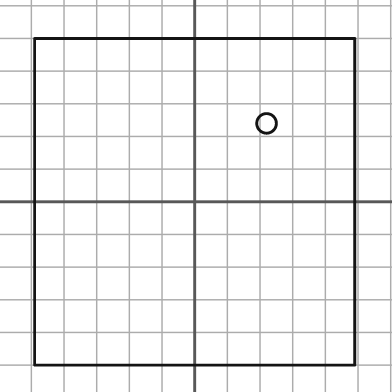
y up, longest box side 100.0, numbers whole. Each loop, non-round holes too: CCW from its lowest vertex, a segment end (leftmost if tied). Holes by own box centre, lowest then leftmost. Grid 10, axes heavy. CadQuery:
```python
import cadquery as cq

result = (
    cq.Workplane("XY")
    .moveTo(-49.0, -50.0)
    .lineTo(49.0, -50.0)
    .lineTo(49.0, 50.0)
    .lineTo(-49.0, 50.0)
    .close()
    .moveTo(22.0, 24.0)
    .circle(3.0)
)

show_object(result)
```